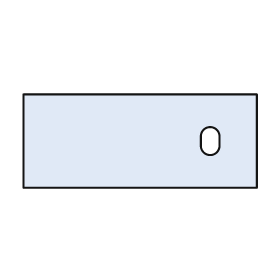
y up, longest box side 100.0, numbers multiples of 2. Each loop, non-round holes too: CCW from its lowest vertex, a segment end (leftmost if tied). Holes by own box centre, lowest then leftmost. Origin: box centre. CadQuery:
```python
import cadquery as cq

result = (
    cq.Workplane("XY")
    .moveTo(-50.0, -20.0)
    .lineTo(50.0, -20.0)
    .lineTo(50.0, 20.0)
    .lineTo(-50.0, 20.0)
    .close()
    .moveTo(26.0, -2.0)
    .threePointArc((30.0, -6.0), (34.0, -2.0))
    .lineTo(34.0, 2.0)
    .threePointArc((30.0, 6.0), (26.0, 2.0))
    .close()
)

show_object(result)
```